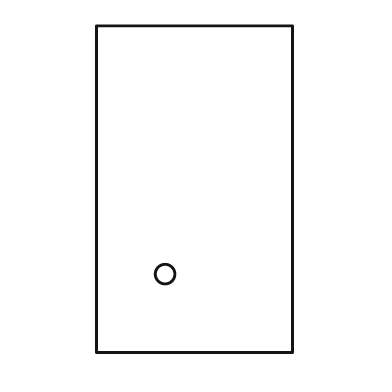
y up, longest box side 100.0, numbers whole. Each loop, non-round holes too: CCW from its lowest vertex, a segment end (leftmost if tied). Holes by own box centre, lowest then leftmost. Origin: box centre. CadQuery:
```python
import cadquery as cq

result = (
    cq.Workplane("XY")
    .moveTo(-30.0, -50.0)
    .lineTo(30.0, -50.0)
    .lineTo(30.0, 50.0)
    .lineTo(-30.0, 50.0)
    .close()
    .moveTo(-9.0, -26.0)
    .circle(3.0)
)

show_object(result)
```